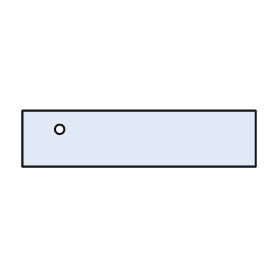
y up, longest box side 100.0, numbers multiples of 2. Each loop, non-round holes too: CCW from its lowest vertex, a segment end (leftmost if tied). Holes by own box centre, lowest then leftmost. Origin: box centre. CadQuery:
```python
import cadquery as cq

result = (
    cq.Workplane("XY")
    .moveTo(-50.0, -12.0)
    .lineTo(50.0, -12.0)
    .lineTo(50.0, 12.0)
    .lineTo(-50.0, 12.0)
    .close()
    .moveTo(-34.0, 4.0)
    .circle(2.0)
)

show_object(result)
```